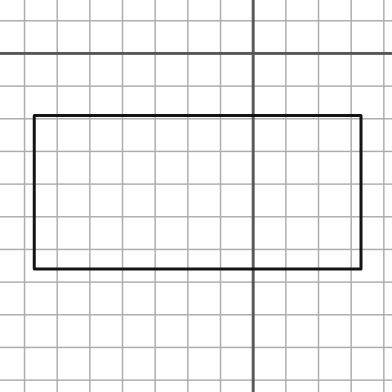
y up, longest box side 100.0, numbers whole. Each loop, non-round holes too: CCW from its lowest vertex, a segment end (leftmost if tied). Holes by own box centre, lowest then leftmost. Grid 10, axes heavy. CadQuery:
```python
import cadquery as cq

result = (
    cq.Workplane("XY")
    .moveTo(-67.0, -66.0)
    .lineTo(33.0, -66.0)
    .lineTo(33.0, -19.0)
    .lineTo(-67.0, -19.0)
    .close()
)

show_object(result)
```